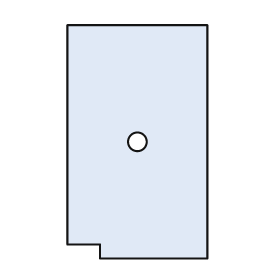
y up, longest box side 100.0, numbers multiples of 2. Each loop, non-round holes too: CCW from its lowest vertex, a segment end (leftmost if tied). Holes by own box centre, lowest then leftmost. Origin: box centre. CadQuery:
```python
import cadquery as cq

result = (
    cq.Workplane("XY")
    .moveTo(-16.0, -50.0)
    .lineTo(30.0, -50.0)
    .lineTo(30.0, 50.0)
    .lineTo(-30.0, 50.0)
    .lineTo(-30.0, -44.0)
    .lineTo(-16.0, -44.0)
    .close()
    .moveTo(0.0, 0.0)
    .circle(4.0)
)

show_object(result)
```